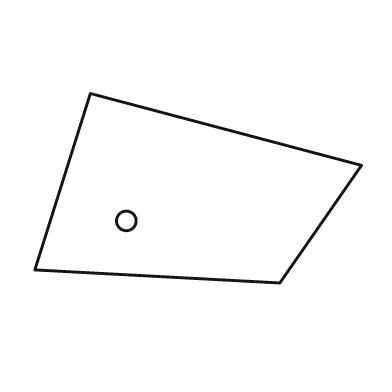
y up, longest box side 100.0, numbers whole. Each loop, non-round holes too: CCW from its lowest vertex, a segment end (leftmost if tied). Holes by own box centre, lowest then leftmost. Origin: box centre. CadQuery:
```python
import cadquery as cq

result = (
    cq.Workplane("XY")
    .moveTo(25.0, -29.0)
    .lineTo(50.0, 7.0)
    .lineTo(-33.0, 29.0)
    .lineTo(-50.0, -25.0)
    .close()
    .moveTo(-22.0, -10.0)
    .circle(3.0)
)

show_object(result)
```